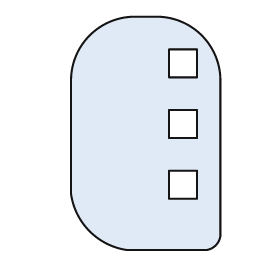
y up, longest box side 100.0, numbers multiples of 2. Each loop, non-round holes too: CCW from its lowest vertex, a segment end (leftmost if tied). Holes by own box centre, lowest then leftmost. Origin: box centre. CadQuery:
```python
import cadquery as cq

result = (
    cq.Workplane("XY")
    .moveTo(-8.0, -50.0)
    .lineTo(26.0, -50.0)
    .threePointArc((30.0, -48.0), (32.0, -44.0))
    .lineTo(32.0, 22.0)
    .threePointArc((24.0, 42.0), (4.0, 50.0))
    .lineTo(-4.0, 50.0)
    .threePointArc((-24.0, 42.0), (-32.0, 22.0))
    .lineTo(-32.0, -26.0)
    .threePointArc((-24.0, -42.0), (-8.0, -50.0))
    .close()
    .moveTo(10.0, -28.0)
    .lineTo(22.0, -28.0)
    .lineTo(22.0, -16.0)
    .lineTo(10.0, -16.0)
    .close()
    .moveTo(10.0, -2.0)
    .lineTo(22.0, -2.0)
    .lineTo(22.0, 10.0)
    .lineTo(10.0, 10.0)
    .close()
    .moveTo(10.0, 24.0)
    .lineTo(22.0, 24.0)
    .lineTo(22.0, 36.0)
    .lineTo(10.0, 36.0)
    .close()
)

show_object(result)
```